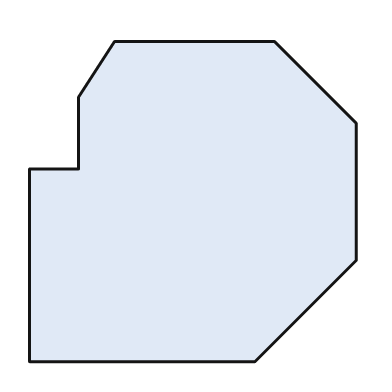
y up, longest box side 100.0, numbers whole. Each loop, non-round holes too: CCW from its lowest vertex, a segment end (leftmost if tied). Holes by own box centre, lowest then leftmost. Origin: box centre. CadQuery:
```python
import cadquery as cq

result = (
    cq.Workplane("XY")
    .moveTo(-50.0, -49.0)
    .lineTo(19.0, -49.0)
    .lineTo(50.0, -18.0)
    .lineTo(50.0, 24.0)
    .lineTo(25.0, 49.0)
    .lineTo(-24.0, 49.0)
    .lineTo(-35.0, 32.0)
    .lineTo(-35.0, 10.0)
    .lineTo(-50.0, 10.0)
    .close()
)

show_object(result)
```